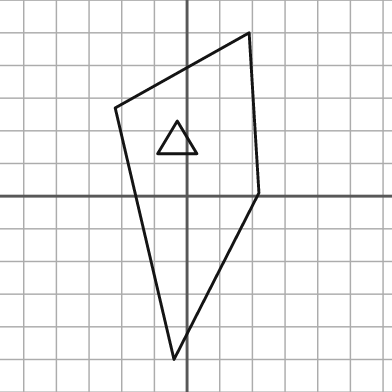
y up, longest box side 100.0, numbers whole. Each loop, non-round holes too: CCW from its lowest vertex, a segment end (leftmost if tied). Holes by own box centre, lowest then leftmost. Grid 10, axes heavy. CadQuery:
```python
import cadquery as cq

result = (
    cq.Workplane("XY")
    .moveTo(-4.0, -50.0)
    .lineTo(22.0, 1.0)
    .lineTo(19.0, 50.0)
    .lineTo(-22.0, 27.0)
    .close()
    .moveTo(-9.0, 13.0)
    .lineTo(3.0, 13.0)
    .lineTo(-3.0, 23.0)
    .close()
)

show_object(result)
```